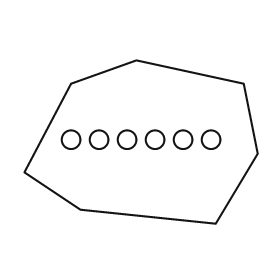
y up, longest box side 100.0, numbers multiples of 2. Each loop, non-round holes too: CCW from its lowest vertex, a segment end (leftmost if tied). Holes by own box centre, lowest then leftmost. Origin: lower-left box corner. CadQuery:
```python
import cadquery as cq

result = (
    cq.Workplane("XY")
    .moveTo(82.0, 0.0)
    .lineTo(100.0, 30.0)
    .lineTo(94.0, 60.0)
    .lineTo(48.0, 70.0)
    .lineTo(20.0, 60.0)
    .lineTo(0.0, 22.0)
    .lineTo(24.0, 6.0)
    .close()
    .moveTo(20.0, 36.0)
    .circle(4.0)
    .moveTo(32.0, 36.0)
    .circle(4.0)
    .moveTo(44.0, 36.0)
    .circle(4.0)
    .moveTo(56.0, 36.0)
    .circle(4.0)
    .moveTo(68.0, 36.0)
    .circle(4.0)
    .moveTo(80.0, 36.0)
    .circle(4.0)
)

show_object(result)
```